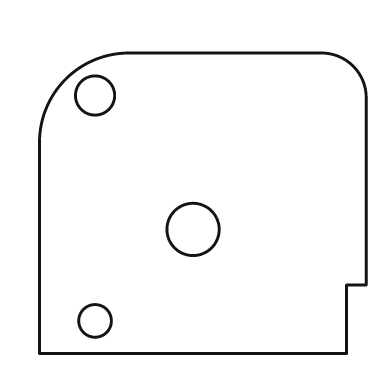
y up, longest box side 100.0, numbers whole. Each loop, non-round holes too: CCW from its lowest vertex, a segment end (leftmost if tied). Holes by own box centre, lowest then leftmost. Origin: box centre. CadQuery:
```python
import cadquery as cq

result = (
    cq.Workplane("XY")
    .moveTo(-50.0, -46.0)
    .lineTo(44.0, -46.0)
    .lineTo(44.0, -25.0)
    .lineTo(50.0, -25.0)
    .lineTo(50.0, 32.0)
    .threePointArc((46.0, 42.0), (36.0, 46.0))
    .lineTo(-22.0, 46.0)
    .threePointArc((-42.0, 38.0), (-50.0, 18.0))
    .close()
    .moveTo(-33.0, -36.0)
    .circle(5.0)
    .moveTo(-3.0, -8.0)
    .circle(8.0)
    .moveTo(-33.0, 33.0)
    .circle(6.0)
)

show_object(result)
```